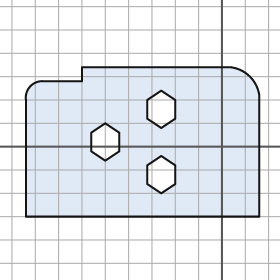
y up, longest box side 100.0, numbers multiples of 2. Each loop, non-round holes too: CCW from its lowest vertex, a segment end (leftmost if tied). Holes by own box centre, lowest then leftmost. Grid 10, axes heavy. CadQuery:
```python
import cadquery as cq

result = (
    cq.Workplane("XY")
    .moveTo(-84.0, -30.0)
    .lineTo(16.0, -30.0)
    .lineTo(16.0, 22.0)
    .threePointArc((12.0, 30.0), (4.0, 34.0))
    .lineTo(-60.0, 34.0)
    .lineTo(-60.0, 28.0)
    .lineTo(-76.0, 28.0)
    .threePointArc((-82.0, 26.0), (-84.0, 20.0))
    .close()
    .moveTo(-26.0, -20.0)
    .lineTo(-20.0, -16.0)
    .lineTo(-20.0, -8.0)
    .lineTo(-26.0, -4.0)
    .lineTo(-32.0, -8.0)
    .lineTo(-32.0, -16.0)
    .close()
    .moveTo(-50.0, -6.0)
    .lineTo(-44.0, -2.0)
    .lineTo(-44.0, 6.0)
    .lineTo(-50.0, 10.0)
    .lineTo(-56.0, 6.0)
    .lineTo(-56.0, -2.0)
    .close()
    .moveTo(-26.0, 8.0)
    .lineTo(-20.0, 12.0)
    .lineTo(-20.0, 20.0)
    .lineTo(-26.0, 24.0)
    .lineTo(-32.0, 20.0)
    .lineTo(-32.0, 12.0)
    .close()
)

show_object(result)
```